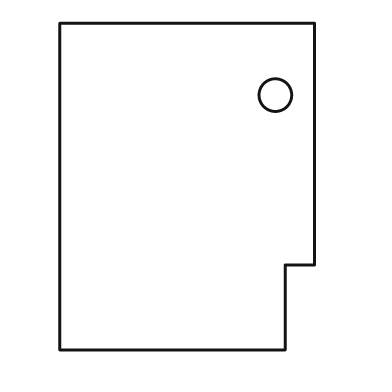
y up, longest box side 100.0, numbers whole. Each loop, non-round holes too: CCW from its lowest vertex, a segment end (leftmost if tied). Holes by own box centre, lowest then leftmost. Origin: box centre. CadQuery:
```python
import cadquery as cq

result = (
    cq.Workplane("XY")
    .moveTo(-39.0, -50.0)
    .lineTo(30.0, -50.0)
    .lineTo(30.0, -24.0)
    .lineTo(39.0, -24.0)
    .lineTo(39.0, 50.0)
    .lineTo(-39.0, 50.0)
    .close()
    .moveTo(27.0, 28.0)
    .circle(5.0)
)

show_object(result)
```